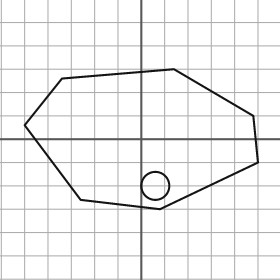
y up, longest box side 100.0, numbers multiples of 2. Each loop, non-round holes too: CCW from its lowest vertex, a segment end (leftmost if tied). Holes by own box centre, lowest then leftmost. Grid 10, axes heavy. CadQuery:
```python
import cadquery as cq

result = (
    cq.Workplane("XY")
    .moveTo(8.0, -30.0)
    .lineTo(50.0, -10.0)
    .lineTo(48.0, 10.0)
    .lineTo(14.0, 30.0)
    .lineTo(-34.0, 26.0)
    .lineTo(-50.0, 6.0)
    .lineTo(-26.0, -26.0)
    .close()
    .moveTo(6.0, -20.0)
    .circle(6.0)
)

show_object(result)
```